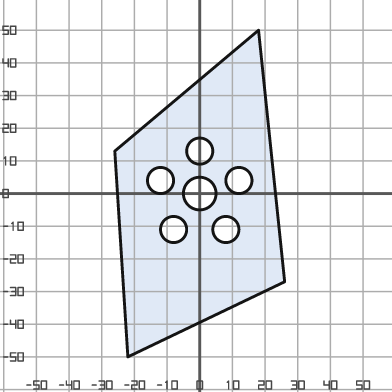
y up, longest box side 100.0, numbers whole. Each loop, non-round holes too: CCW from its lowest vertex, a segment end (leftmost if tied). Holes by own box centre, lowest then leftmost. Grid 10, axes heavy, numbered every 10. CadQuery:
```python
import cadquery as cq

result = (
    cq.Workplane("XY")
    .moveTo(-22.0, -50.0)
    .lineTo(26.0, -27.0)
    .lineTo(18.0, 50.0)
    .lineTo(-26.0, 13.0)
    .close()
    .moveTo(-8.0, -11.0)
    .circle(4.0)
    .moveTo(8.0, -11.0)
    .circle(4.0)
    .moveTo(0.0, 0.0)
    .circle(5.0)
    .moveTo(-12.0, 4.0)
    .circle(4.0)
    .moveTo(12.0, 4.0)
    .circle(4.0)
    .moveTo(0.0, 13.0)
    .circle(4.0)
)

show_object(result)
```